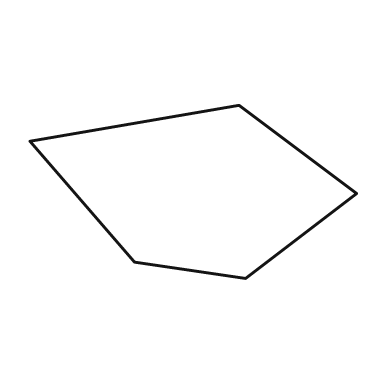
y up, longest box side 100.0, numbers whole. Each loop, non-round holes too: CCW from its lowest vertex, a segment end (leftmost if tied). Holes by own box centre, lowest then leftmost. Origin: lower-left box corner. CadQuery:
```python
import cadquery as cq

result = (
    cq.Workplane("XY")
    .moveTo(66.0, 0.0)
    .lineTo(100.0, 26.0)
    .lineTo(64.0, 53.0)
    .lineTo(0.0, 42.0)
    .lineTo(32.0, 5.0)
    .close()
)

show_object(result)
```